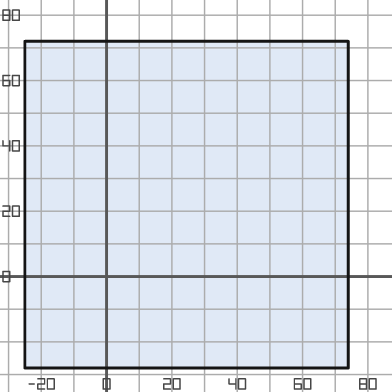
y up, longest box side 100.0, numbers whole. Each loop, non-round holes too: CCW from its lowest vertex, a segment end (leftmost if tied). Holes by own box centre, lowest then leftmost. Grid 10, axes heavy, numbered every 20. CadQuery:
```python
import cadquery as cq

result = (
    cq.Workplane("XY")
    .moveTo(-25.0, -28.0)
    .lineTo(74.0, -28.0)
    .lineTo(74.0, 72.0)
    .lineTo(-25.0, 72.0)
    .close()
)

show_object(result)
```